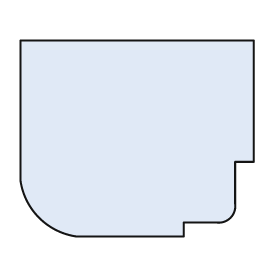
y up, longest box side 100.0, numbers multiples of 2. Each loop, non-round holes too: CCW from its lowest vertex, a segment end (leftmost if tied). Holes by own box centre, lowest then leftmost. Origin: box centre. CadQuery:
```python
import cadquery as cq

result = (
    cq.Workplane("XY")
    .moveTo(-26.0, -42.0)
    .lineTo(20.0, -42.0)
    .lineTo(20.0, -36.0)
    .lineTo(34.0, -36.0)
    .threePointArc((40.0, -34.0), (42.0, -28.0))
    .lineTo(42.0, -10.0)
    .lineTo(50.0, -10.0)
    .lineTo(50.0, 42.0)
    .lineTo(-50.0, 42.0)
    .lineTo(-50.0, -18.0)
    .threePointArc((-42.0, -34.0), (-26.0, -42.0))
    .close()
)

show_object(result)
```